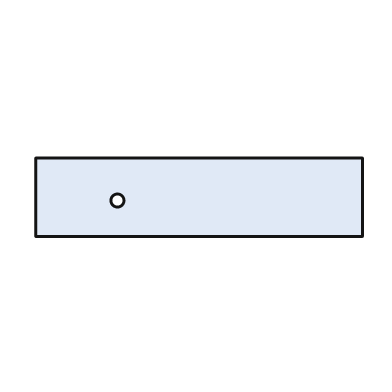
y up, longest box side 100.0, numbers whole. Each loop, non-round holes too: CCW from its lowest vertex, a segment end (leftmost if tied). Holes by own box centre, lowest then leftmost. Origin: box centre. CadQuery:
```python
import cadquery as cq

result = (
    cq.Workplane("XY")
    .moveTo(-50.0, -12.0)
    .lineTo(50.0, -12.0)
    .lineTo(50.0, 12.0)
    .lineTo(-50.0, 12.0)
    .close()
    .moveTo(-25.0, -1.0)
    .circle(2.0)
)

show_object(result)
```